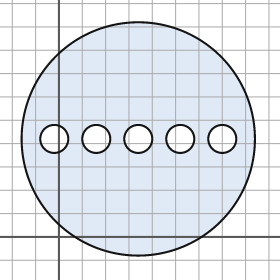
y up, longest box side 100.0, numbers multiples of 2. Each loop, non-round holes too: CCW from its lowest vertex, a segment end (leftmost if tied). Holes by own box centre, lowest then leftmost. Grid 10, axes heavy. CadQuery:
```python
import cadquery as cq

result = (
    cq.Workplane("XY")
    .moveTo(34.0, 42.0)
    .circle(50.0)
    .moveTo(-2.0, 42.0)
    .circle(6.0)
    .moveTo(16.0, 42.0)
    .circle(6.0)
    .moveTo(34.0, 42.0)
    .circle(6.0)
    .moveTo(52.0, 42.0)
    .circle(6.0)
    .moveTo(70.0, 42.0)
    .circle(6.0)
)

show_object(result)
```